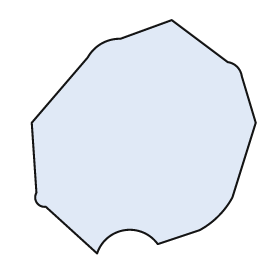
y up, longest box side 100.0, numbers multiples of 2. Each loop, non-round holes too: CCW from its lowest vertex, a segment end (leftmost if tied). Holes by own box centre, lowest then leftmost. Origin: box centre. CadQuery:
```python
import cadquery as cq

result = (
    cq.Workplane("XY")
    .moveTo(-20.0, -50.0)
    .threePointArc((-8.0, -40.0), (6.0, -46.0))
    .lineTo(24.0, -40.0)
    .threePointArc((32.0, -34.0), (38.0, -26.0))
    .lineTo(48.0, 6.0)
    .lineTo(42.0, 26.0)
    .threePointArc((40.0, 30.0), (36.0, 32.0))
    .lineTo(12.0, 50.0)
    .lineTo(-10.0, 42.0)
    .threePointArc((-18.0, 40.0), (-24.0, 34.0))
    .lineTo(-48.0, 6.0)
    .lineTo(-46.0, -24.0)
    .threePointArc((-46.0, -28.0), (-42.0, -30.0))
    .close()
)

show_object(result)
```